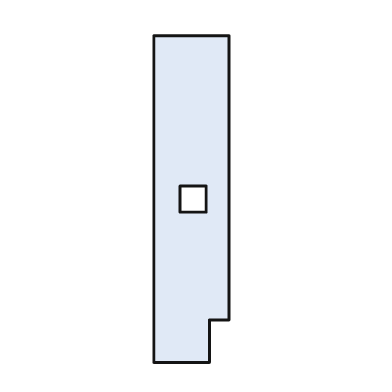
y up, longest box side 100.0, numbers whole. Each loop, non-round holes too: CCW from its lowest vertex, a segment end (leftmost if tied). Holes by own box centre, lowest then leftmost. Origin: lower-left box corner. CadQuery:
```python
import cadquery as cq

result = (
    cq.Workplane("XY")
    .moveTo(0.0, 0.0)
    .lineTo(17.0, 0.0)
    .lineTo(17.0, 13.0)
    .lineTo(23.0, 13.0)
    .lineTo(23.0, 100.0)
    .lineTo(0.0, 100.0)
    .close()
    .moveTo(8.0, 46.0)
    .lineTo(16.0, 46.0)
    .lineTo(16.0, 54.0)
    .lineTo(8.0, 54.0)
    .close()
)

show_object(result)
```